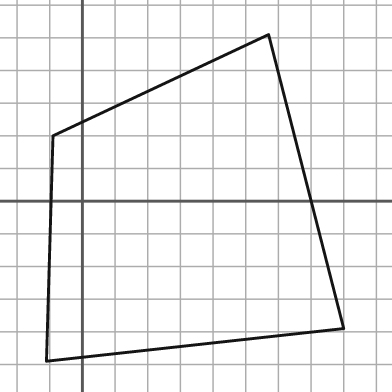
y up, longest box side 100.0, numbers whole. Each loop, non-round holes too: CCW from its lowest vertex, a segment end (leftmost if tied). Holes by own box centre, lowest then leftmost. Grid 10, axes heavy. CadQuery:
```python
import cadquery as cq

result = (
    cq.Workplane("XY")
    .moveTo(-11.0, -49.0)
    .lineTo(80.0, -39.0)
    .lineTo(57.0, 51.0)
    .lineTo(-9.0, 20.0)
    .close()
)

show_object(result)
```